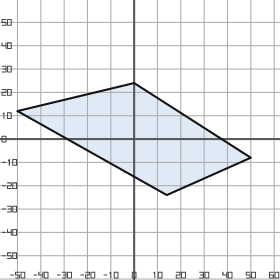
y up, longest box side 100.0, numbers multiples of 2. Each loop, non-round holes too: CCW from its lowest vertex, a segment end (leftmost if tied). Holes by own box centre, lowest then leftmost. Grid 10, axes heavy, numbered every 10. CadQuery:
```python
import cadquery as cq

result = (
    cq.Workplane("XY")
    .moveTo(14.0, -24.0)
    .lineTo(50.0, -8.0)
    .lineTo(0.0, 24.0)
    .lineTo(-50.0, 12.0)
    .close()
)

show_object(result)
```